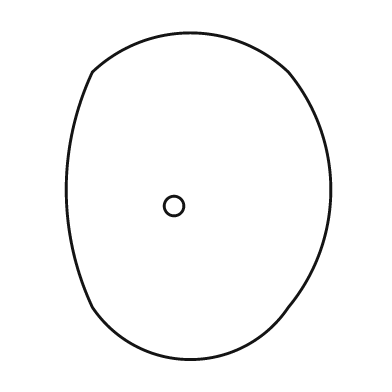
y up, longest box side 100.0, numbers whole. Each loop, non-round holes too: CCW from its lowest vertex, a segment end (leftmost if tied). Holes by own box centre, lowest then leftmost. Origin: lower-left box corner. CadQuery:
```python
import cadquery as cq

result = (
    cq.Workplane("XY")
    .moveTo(8.0, 16.0)
    .threePointArc((38.0, 0.0), (68.0, 16.0))
    .threePointArc((81.0, 52.0), (68.0, 88.0))
    .threePointArc((38.0, 100.0), (8.0, 88.0))
    .threePointArc((0.0, 52.0), (8.0, 16.0))
    .close()
    .moveTo(33.0, 47.0)
    .circle(3.0)
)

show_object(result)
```